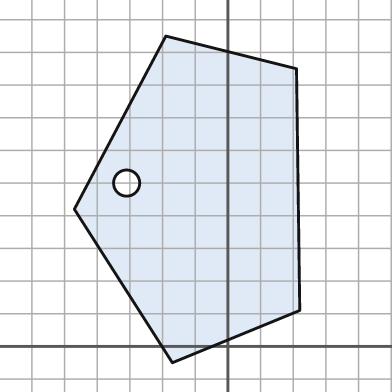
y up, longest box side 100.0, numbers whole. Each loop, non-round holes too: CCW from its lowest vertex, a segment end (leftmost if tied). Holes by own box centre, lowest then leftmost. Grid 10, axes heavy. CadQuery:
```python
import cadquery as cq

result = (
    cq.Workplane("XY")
    .moveTo(-17.0, -5.0)
    .lineTo(22.0, 11.0)
    .lineTo(21.0, 85.0)
    .lineTo(-19.0, 95.0)
    .lineTo(-47.0, 42.0)
    .close()
    .moveTo(-31.0, 50.0)
    .circle(4.0)
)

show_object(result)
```